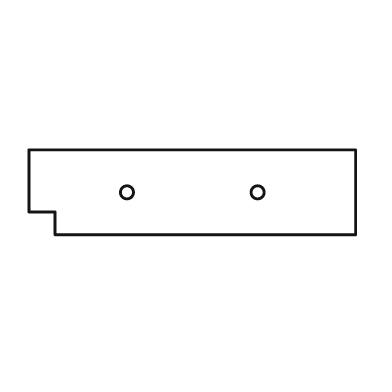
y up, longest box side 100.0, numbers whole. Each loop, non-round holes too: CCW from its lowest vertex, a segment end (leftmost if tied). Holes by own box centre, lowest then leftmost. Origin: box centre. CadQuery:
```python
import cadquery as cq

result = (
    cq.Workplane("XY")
    .moveTo(-42.0, -13.0)
    .lineTo(50.0, -13.0)
    .lineTo(50.0, 13.0)
    .lineTo(-50.0, 13.0)
    .lineTo(-50.0, -6.0)
    .lineTo(-42.0, -6.0)
    .close()
    .moveTo(-20.0, 0.0)
    .circle(2.0)
    .moveTo(20.0, 0.0)
    .circle(2.0)
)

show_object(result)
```